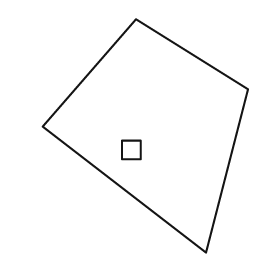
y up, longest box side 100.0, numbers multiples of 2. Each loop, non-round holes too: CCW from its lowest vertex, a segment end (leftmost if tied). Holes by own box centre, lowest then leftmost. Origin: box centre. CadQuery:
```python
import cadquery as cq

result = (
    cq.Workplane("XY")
    .moveTo(26.0, -50.0)
    .lineTo(44.0, 20.0)
    .lineTo(-4.0, 50.0)
    .lineTo(-44.0, 4.0)
    .close()
    .moveTo(-10.0, -10.0)
    .lineTo(-2.0, -10.0)
    .lineTo(-2.0, -2.0)
    .lineTo(-10.0, -2.0)
    .close()
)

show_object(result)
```